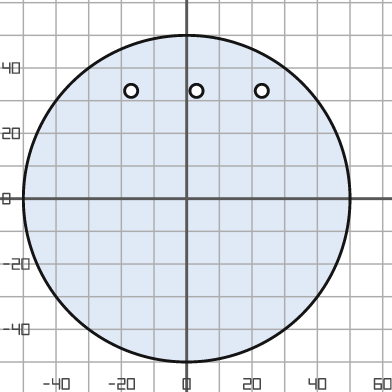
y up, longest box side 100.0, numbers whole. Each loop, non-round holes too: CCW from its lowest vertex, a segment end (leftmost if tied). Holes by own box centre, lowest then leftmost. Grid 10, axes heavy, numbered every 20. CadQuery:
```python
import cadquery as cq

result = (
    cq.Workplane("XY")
    .moveTo(0.0, 0.0)
    .circle(50.0)
    .moveTo(-17.0, 33.0)
    .circle(2.0)
    .moveTo(3.0, 33.0)
    .circle(2.0)
    .moveTo(23.0, 33.0)
    .circle(2.0)
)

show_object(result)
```